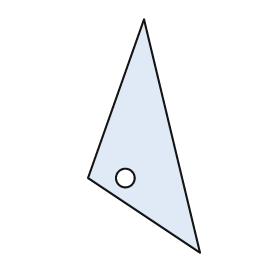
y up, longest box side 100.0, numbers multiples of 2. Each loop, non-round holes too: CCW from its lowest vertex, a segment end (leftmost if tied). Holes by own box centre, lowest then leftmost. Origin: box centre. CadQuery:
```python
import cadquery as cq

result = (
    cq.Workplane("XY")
    .moveTo(24.0, -50.0)
    .lineTo(0.0, 50.0)
    .lineTo(-24.0, -18.0)
    .close()
    .moveTo(-8.0, -18.0)
    .circle(4.0)
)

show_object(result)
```